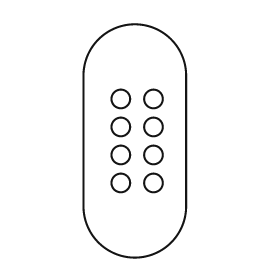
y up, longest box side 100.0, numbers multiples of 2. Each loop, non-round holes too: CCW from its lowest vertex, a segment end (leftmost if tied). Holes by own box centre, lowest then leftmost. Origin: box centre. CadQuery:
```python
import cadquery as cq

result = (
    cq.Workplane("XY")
    .moveTo(-22.0, -28.0)
    .threePointArc((0.0, -50.0), (22.0, -28.0))
    .lineTo(22.0, 28.0)
    .threePointArc((0.0, 50.0), (-22.0, 28.0))
    .close()
    .moveTo(-6.0, -18.0)
    .circle(4.0)
    .moveTo(8.0, -18.0)
    .circle(4.0)
    .moveTo(-6.0, -6.0)
    .circle(4.0)
    .moveTo(8.0, -6.0)
    .circle(4.0)
    .moveTo(-6.0, 6.0)
    .circle(4.0)
    .moveTo(8.0, 6.0)
    .circle(4.0)
    .moveTo(-6.0, 18.0)
    .circle(4.0)
    .moveTo(8.0, 18.0)
    .circle(4.0)
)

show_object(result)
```